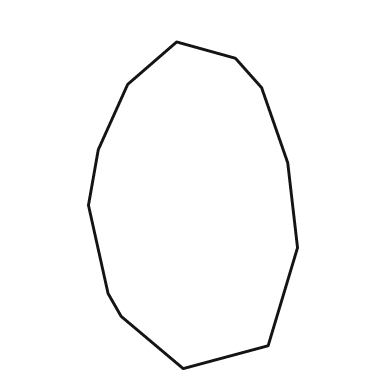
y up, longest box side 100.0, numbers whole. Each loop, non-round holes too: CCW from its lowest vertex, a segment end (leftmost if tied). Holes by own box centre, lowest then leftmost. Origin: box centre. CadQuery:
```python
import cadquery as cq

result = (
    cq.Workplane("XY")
    .moveTo(-3.0, -50.0)
    .lineTo(23.0, -43.0)
    .lineTo(32.0, -13.0)
    .lineTo(29.0, 13.0)
    .lineTo(21.0, 36.0)
    .lineTo(13.0, 45.0)
    .lineTo(-5.0, 50.0)
    .lineTo(-20.0, 37.0)
    .lineTo(-29.0, 17.0)
    .lineTo(-32.0, 0.0)
    .lineTo(-26.0, -27.0)
    .lineTo(-22.0, -34.0)
    .close()
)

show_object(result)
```